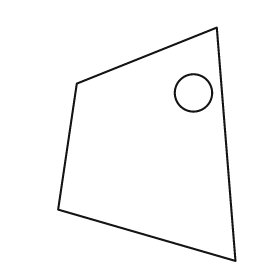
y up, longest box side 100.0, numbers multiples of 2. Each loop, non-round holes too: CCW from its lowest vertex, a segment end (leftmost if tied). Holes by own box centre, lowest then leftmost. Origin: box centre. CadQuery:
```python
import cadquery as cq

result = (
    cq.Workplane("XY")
    .moveTo(38.0, -50.0)
    .lineTo(30.0, 50.0)
    .lineTo(-30.0, 26.0)
    .lineTo(-38.0, -28.0)
    .close()
    .moveTo(20.0, 22.0)
    .circle(8.0)
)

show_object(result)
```